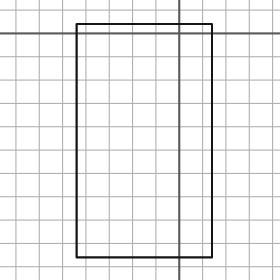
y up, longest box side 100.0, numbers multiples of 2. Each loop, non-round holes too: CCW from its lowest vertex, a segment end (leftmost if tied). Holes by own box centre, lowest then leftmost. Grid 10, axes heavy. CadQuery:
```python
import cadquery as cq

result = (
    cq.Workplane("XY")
    .moveTo(-44.0, -96.0)
    .lineTo(14.0, -96.0)
    .lineTo(14.0, 4.0)
    .lineTo(-44.0, 4.0)
    .close()
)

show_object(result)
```